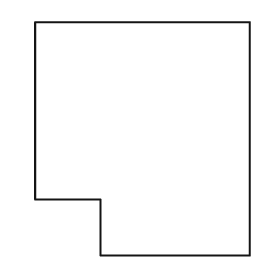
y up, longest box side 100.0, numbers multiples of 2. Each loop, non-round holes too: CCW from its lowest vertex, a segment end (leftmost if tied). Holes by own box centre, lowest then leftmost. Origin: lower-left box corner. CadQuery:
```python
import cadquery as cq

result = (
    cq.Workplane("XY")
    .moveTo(28.0, 0.0)
    .lineTo(92.0, 0.0)
    .lineTo(92.0, 100.0)
    .lineTo(0.0, 100.0)
    .lineTo(0.0, 24.0)
    .lineTo(28.0, 24.0)
    .close()
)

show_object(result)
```